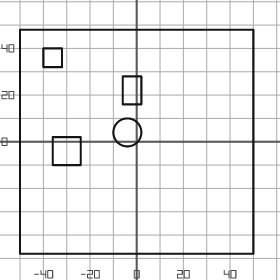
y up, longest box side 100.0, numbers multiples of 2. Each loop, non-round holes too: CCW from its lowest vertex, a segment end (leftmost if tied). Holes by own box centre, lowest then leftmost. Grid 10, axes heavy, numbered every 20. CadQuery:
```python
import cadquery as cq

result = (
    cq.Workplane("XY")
    .moveTo(-50.0, -48.0)
    .lineTo(50.0, -48.0)
    .lineTo(50.0, 48.0)
    .lineTo(-50.0, 48.0)
    .close()
    .moveTo(-36.0, -10.0)
    .lineTo(-24.0, -10.0)
    .lineTo(-24.0, 2.0)
    .lineTo(-36.0, 2.0)
    .close()
    .moveTo(-4.0, 4.0)
    .circle(6.0)
    .moveTo(-6.0, 16.0)
    .lineTo(2.0, 16.0)
    .lineTo(2.0, 28.0)
    .lineTo(-6.0, 28.0)
    .close()
    .moveTo(-40.0, 32.0)
    .lineTo(-32.0, 32.0)
    .lineTo(-32.0, 40.0)
    .lineTo(-40.0, 40.0)
    .close()
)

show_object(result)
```